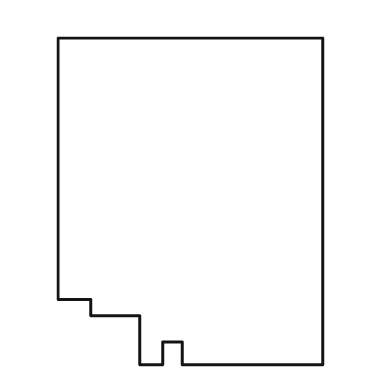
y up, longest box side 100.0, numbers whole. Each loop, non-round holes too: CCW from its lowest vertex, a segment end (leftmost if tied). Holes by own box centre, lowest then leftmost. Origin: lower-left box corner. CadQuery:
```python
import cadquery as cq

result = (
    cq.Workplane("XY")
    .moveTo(25.0, 0.0)
    .lineTo(32.0, 0.0)
    .lineTo(32.0, 7.0)
    .lineTo(38.0, 7.0)
    .lineTo(38.0, 0.0)
    .lineTo(81.0, 0.0)
    .lineTo(81.0, 100.0)
    .lineTo(0.0, 100.0)
    .lineTo(0.0, 20.0)
    .lineTo(10.0, 20.0)
    .lineTo(10.0, 15.0)
    .lineTo(25.0, 15.0)
    .close()
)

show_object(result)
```